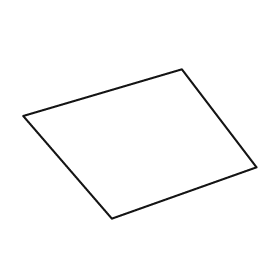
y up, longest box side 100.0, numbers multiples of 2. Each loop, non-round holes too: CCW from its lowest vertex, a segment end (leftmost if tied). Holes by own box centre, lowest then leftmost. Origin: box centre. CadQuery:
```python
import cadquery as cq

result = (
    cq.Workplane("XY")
    .moveTo(-12.0, -32.0)
    .lineTo(50.0, -10.0)
    .lineTo(18.0, 32.0)
    .lineTo(-50.0, 12.0)
    .close()
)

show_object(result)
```